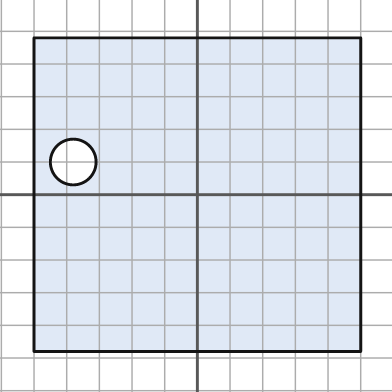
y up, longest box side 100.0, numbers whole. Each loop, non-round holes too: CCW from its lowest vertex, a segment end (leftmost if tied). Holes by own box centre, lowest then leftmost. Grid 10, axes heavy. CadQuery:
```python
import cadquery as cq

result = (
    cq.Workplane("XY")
    .moveTo(-50.0, -48.0)
    .lineTo(50.0, -48.0)
    .lineTo(50.0, 48.0)
    .lineTo(-50.0, 48.0)
    .close()
    .moveTo(-38.0, 10.0)
    .circle(7.0)
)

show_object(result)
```